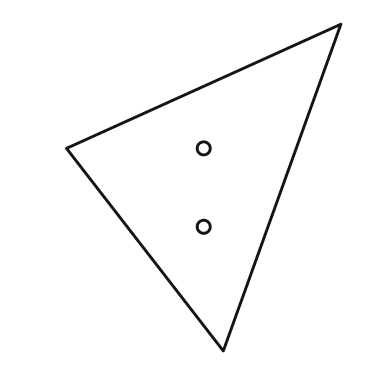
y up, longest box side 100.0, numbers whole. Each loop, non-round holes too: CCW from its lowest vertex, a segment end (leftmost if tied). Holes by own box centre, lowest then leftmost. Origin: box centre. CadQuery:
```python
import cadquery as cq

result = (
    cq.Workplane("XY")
    .moveTo(6.0, -50.0)
    .lineTo(42.0, 50.0)
    .lineTo(-42.0, 12.0)
    .close()
    .moveTo(0.0, -12.0)
    .circle(2.0)
    .moveTo(0.0, 12.0)
    .circle(2.0)
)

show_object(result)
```